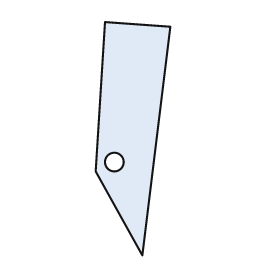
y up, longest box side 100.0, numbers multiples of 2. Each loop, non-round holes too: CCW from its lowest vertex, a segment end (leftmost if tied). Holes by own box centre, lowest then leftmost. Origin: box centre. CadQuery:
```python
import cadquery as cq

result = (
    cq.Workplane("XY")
    .moveTo(4.0, -50.0)
    .lineTo(16.0, 48.0)
    .lineTo(-12.0, 50.0)
    .lineTo(-16.0, -14.0)
    .close()
    .moveTo(-8.0, -10.0)
    .circle(4.0)
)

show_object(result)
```